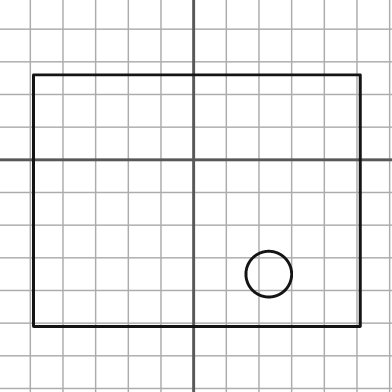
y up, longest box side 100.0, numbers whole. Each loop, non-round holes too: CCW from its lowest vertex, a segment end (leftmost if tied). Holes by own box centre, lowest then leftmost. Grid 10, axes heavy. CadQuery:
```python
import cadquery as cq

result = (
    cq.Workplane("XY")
    .moveTo(-49.0, -51.0)
    .lineTo(51.0, -51.0)
    .lineTo(51.0, 26.0)
    .lineTo(-49.0, 26.0)
    .close()
    .moveTo(23.0, -35.0)
    .circle(7.0)
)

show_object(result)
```